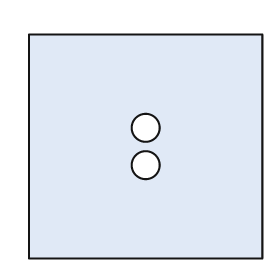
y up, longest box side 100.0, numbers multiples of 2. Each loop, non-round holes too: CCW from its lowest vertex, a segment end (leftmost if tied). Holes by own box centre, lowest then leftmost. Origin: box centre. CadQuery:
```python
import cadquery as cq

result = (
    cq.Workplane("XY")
    .moveTo(-50.0, -48.0)
    .lineTo(50.0, -48.0)
    .lineTo(50.0, 48.0)
    .lineTo(-50.0, 48.0)
    .close()
    .moveTo(0.0, -8.0)
    .circle(6.0)
    .moveTo(0.0, 8.0)
    .circle(6.0)
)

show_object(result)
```